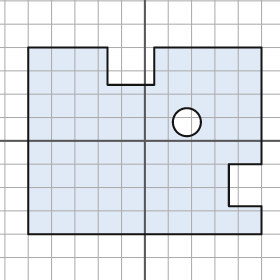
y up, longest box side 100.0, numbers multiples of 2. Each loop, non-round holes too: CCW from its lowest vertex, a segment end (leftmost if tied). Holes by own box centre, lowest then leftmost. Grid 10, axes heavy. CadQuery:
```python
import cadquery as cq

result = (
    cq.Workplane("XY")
    .moveTo(-50.0, -40.0)
    .lineTo(50.0, -40.0)
    .lineTo(50.0, -28.0)
    .lineTo(36.0, -28.0)
    .lineTo(36.0, -10.0)
    .lineTo(50.0, -10.0)
    .lineTo(50.0, 40.0)
    .lineTo(4.0, 40.0)
    .lineTo(4.0, 24.0)
    .lineTo(-16.0, 24.0)
    .lineTo(-16.0, 40.0)
    .lineTo(-50.0, 40.0)
    .close()
    .moveTo(18.0, 8.0)
    .circle(6.0)
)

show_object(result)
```